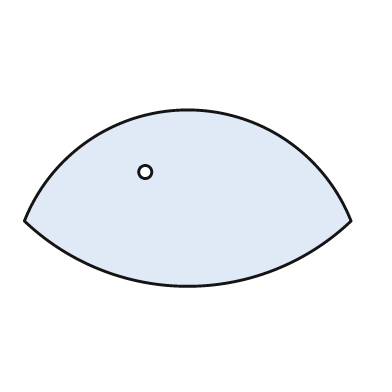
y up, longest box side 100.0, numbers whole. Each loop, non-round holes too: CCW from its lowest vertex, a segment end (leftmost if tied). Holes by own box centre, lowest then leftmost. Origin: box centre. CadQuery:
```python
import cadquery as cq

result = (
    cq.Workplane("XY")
    .moveTo(-50.0, -7.0)
    .threePointArc((0.0, -27.0), (50.0, -7.0))
    .threePointArc((0.0, 27.0), (-50.0, -7.0))
    .close()
    .moveTo(-13.0, 8.0)
    .circle(2.0)
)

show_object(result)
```